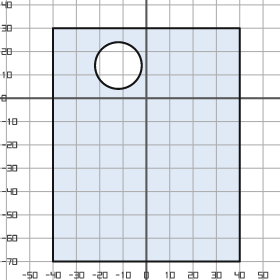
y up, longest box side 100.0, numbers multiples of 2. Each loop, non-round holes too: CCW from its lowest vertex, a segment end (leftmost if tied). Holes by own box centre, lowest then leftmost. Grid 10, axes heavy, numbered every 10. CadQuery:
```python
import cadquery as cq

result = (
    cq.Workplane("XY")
    .moveTo(-40.0, -70.0)
    .lineTo(40.0, -70.0)
    .lineTo(40.0, 30.0)
    .lineTo(-40.0, 30.0)
    .close()
    .moveTo(-12.0, 14.0)
    .circle(10.0)
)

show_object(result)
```